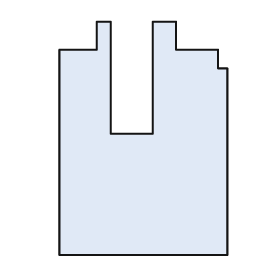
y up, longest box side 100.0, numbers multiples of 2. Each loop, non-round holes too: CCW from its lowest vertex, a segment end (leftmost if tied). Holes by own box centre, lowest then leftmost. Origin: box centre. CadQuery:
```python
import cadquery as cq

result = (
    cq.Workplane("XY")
    .moveTo(-36.0, -50.0)
    .lineTo(36.0, -50.0)
    .lineTo(36.0, 30.0)
    .lineTo(32.0, 30.0)
    .lineTo(32.0, 38.0)
    .lineTo(14.0, 38.0)
    .lineTo(14.0, 50.0)
    .lineTo(4.0, 50.0)
    .lineTo(4.0, 2.0)
    .lineTo(-14.0, 2.0)
    .lineTo(-14.0, 50.0)
    .lineTo(-20.0, 50.0)
    .lineTo(-20.0, 38.0)
    .lineTo(-36.0, 38.0)
    .close()
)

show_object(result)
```